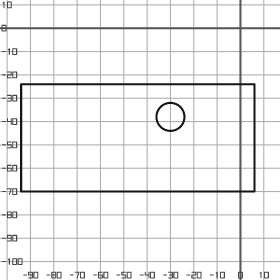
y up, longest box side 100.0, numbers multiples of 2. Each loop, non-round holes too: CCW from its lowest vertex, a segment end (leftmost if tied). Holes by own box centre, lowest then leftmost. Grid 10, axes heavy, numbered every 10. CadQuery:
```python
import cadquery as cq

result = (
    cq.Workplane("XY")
    .moveTo(-94.0, -70.0)
    .lineTo(6.0, -70.0)
    .lineTo(6.0, -24.0)
    .lineTo(-94.0, -24.0)
    .close()
    .moveTo(-30.0, -38.0)
    .circle(6.0)
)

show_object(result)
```